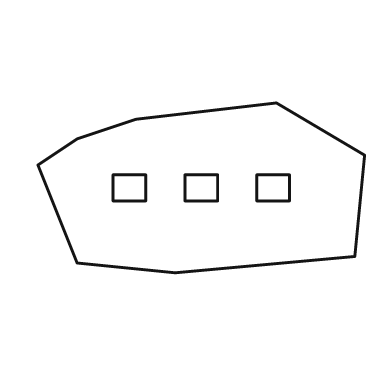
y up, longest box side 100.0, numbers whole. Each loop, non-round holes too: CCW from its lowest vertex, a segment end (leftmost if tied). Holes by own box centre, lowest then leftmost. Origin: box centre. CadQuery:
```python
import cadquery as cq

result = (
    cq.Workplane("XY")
    .moveTo(-8.0, -26.0)
    .lineTo(47.0, -21.0)
    .lineTo(50.0, 10.0)
    .lineTo(23.0, 26.0)
    .lineTo(-20.0, 21.0)
    .lineTo(-38.0, 15.0)
    .lineTo(-50.0, 7.0)
    .lineTo(-38.0, -23.0)
    .close()
    .moveTo(-27.0, -4.0)
    .lineTo(-17.0, -4.0)
    .lineTo(-17.0, 4.0)
    .lineTo(-27.0, 4.0)
    .close()
    .moveTo(-5.0, -4.0)
    .lineTo(5.0, -4.0)
    .lineTo(5.0, 4.0)
    .lineTo(-5.0, 4.0)
    .close()
    .moveTo(17.0, -4.0)
    .lineTo(27.0, -4.0)
    .lineTo(27.0, 4.0)
    .lineTo(17.0, 4.0)
    .close()
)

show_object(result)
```